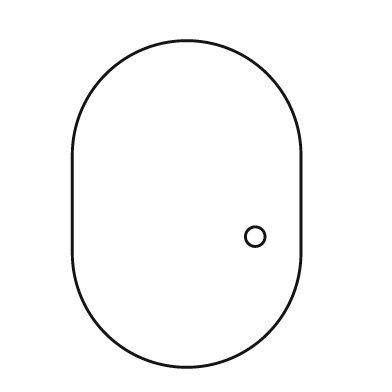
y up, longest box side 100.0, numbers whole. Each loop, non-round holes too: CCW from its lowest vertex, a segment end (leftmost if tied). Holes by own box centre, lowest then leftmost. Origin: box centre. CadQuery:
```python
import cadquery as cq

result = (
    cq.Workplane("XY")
    .moveTo(-35.0, -15.0)
    .threePointArc((0.0, -50.0), (35.0, -15.0))
    .lineTo(35.0, 15.0)
    .threePointArc((0.0, 50.0), (-35.0, 15.0))
    .close()
    .moveTo(21.0, -10.0)
    .circle(3.0)
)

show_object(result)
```